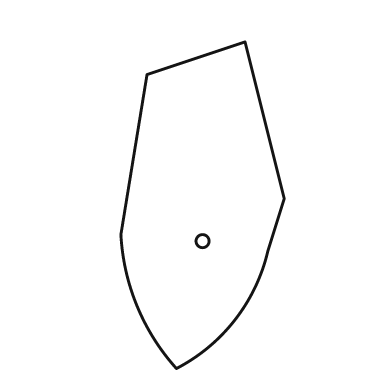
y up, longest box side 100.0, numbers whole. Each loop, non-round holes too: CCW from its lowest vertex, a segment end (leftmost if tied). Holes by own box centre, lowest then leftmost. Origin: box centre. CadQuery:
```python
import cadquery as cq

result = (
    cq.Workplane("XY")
    .moveTo(-8.0, -50.0)
    .threePointArc((10.0, -35.0), (20.0, -14.0))
    .lineTo(25.0, 2.0)
    .lineTo(13.0, 50.0)
    .lineTo(-17.0, 40.0)
    .lineTo(-25.0, -9.0)
    .threePointArc((-20.0, -31.0), (-8.0, -50.0))
    .close()
    .moveTo(0.0, -11.0)
    .circle(2.0)
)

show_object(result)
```